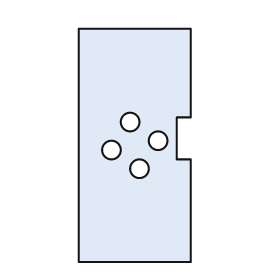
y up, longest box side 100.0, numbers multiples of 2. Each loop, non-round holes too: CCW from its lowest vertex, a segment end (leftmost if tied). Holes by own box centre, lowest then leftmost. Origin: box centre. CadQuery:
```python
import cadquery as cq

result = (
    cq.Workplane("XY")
    .moveTo(-24.0, -50.0)
    .lineTo(24.0, -50.0)
    .lineTo(24.0, -6.0)
    .lineTo(18.0, -6.0)
    .lineTo(18.0, 12.0)
    .lineTo(24.0, 12.0)
    .lineTo(24.0, 50.0)
    .lineTo(-24.0, 50.0)
    .close()
    .moveTo(2.0, -10.0)
    .circle(4.0)
    .moveTo(-10.0, -2.0)
    .circle(4.0)
    .moveTo(10.0, 2.0)
    .circle(4.0)
    .moveTo(-2.0, 10.0)
    .circle(4.0)
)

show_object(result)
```